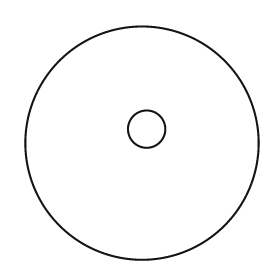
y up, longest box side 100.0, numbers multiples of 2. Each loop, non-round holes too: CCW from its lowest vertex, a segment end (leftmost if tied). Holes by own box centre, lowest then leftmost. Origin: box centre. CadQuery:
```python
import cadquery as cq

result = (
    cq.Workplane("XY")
    .moveTo(0.0, 0.0)
    .circle(50.0)
    .moveTo(2.0, 6.0)
    .circle(8.0)
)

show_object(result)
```